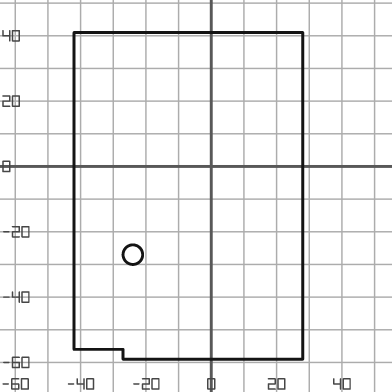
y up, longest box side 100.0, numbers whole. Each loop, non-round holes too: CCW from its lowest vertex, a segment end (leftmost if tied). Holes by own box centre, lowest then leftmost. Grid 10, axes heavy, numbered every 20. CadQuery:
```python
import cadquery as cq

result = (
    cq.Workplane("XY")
    .moveTo(-27.0, -59.0)
    .lineTo(28.0, -59.0)
    .lineTo(28.0, 41.0)
    .lineTo(-42.0, 41.0)
    .lineTo(-42.0, -56.0)
    .lineTo(-27.0, -56.0)
    .close()
    .moveTo(-24.0, -27.0)
    .circle(3.0)
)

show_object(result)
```